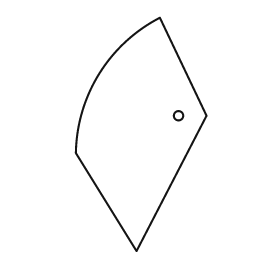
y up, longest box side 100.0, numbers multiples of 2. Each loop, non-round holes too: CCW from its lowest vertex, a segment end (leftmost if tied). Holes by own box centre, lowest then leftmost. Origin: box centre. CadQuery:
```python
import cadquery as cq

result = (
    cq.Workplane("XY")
    .moveTo(-2.0, -50.0)
    .lineTo(28.0, 8.0)
    .lineTo(8.0, 50.0)
    .threePointArc((-18.0, 26.0), (-28.0, -8.0))
    .close()
    .moveTo(16.0, 8.0)
    .circle(2.0)
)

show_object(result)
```